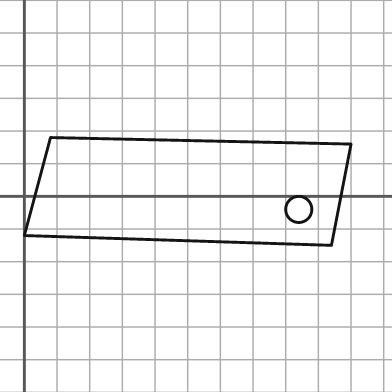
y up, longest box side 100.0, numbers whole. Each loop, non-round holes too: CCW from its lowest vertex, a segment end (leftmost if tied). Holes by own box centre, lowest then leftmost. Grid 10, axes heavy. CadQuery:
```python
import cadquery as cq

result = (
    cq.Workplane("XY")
    .moveTo(94.0, -15.0)
    .lineTo(100.0, 16.0)
    .lineTo(8.0, 18.0)
    .lineTo(0.0, -12.0)
    .close()
    .moveTo(84.0, -4.0)
    .circle(4.0)
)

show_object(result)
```